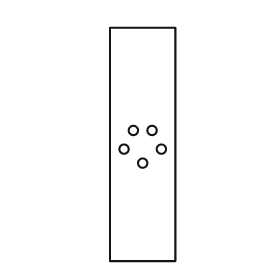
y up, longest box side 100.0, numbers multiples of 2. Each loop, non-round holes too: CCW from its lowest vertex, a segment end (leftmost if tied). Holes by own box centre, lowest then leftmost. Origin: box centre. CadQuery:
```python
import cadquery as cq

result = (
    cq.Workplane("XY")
    .moveTo(-14.0, -50.0)
    .lineTo(14.0, -50.0)
    .lineTo(14.0, 50.0)
    .lineTo(-14.0, 50.0)
    .close()
    .moveTo(0.0, -8.0)
    .circle(2.0)
    .moveTo(-8.0, -2.0)
    .circle(2.0)
    .moveTo(8.0, -2.0)
    .circle(2.0)
    .moveTo(-4.0, 6.0)
    .circle(2.0)
    .moveTo(4.0, 6.0)
    .circle(2.0)
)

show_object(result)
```